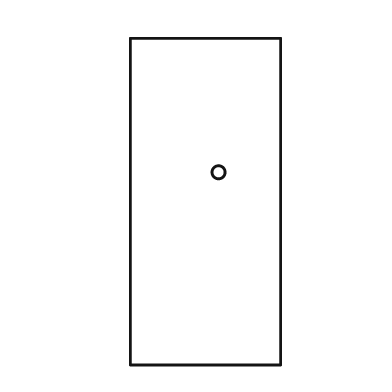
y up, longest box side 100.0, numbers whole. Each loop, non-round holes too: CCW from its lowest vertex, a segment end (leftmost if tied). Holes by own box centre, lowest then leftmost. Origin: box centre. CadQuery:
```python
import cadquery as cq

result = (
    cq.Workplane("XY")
    .moveTo(-23.0, -50.0)
    .lineTo(23.0, -50.0)
    .lineTo(23.0, 50.0)
    .lineTo(-23.0, 50.0)
    .close()
    .moveTo(4.0, 9.0)
    .circle(2.0)
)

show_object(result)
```